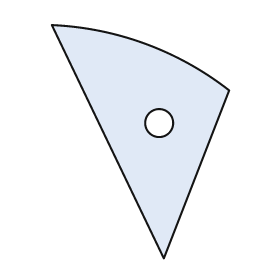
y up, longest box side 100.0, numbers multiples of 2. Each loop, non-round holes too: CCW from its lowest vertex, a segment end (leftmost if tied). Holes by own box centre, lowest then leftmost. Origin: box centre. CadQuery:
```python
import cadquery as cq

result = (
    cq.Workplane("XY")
    .moveTo(10.0, -50.0)
    .lineTo(38.0, 22.0)
    .threePointArc((2.0, 42.0), (-38.0, 50.0))
    .close()
    .moveTo(8.0, 8.0)
    .circle(6.0)
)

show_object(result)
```